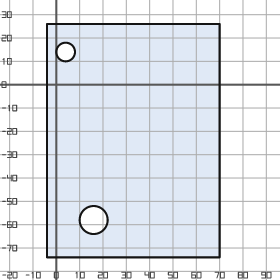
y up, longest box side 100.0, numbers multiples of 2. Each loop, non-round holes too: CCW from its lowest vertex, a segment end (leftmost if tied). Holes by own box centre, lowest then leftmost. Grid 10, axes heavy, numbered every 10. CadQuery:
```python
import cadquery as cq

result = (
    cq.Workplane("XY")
    .moveTo(-4.0, -74.0)
    .lineTo(70.0, -74.0)
    .lineTo(70.0, 26.0)
    .lineTo(-4.0, 26.0)
    .close()
    .moveTo(16.0, -58.0)
    .circle(6.0)
    .moveTo(4.0, 14.0)
    .circle(4.0)
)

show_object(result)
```